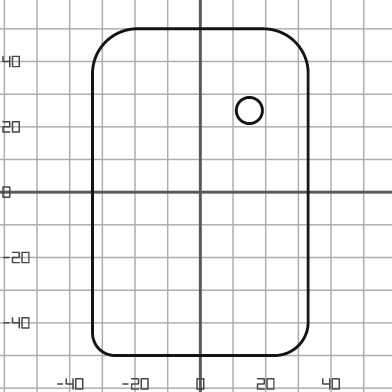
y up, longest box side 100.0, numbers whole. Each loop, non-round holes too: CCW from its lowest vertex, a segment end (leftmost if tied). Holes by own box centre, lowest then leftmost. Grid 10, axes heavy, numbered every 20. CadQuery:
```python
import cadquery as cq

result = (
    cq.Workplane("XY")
    .moveTo(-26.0, -50.0)
    .lineTo(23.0, -50.0)
    .threePointArc((30.0, -47.0), (33.0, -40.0))
    .lineTo(33.0, 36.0)
    .threePointArc((29.0, 46.0), (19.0, 50.0))
    .lineTo(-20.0, 50.0)
    .threePointArc((-29.0, 46.0), (-33.0, 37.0))
    .lineTo(-33.0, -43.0)
    .threePointArc((-31.0, -48.0), (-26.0, -50.0))
    .close()
    .moveTo(15.0, 25.0)
    .circle(4.0)
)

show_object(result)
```